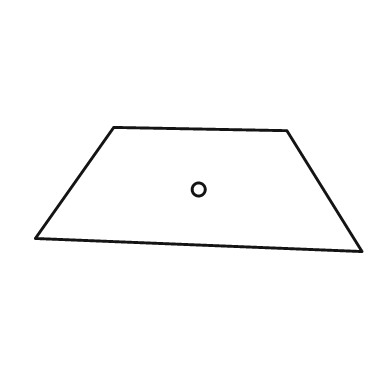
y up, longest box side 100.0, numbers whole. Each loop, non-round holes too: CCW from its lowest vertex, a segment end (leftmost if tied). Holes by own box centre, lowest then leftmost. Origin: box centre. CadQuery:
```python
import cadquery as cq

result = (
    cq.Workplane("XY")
    .moveTo(50.0, -19.0)
    .lineTo(27.0, 18.0)
    .lineTo(-26.0, 19.0)
    .lineTo(-50.0, -15.0)
    .close()
    .moveTo(0.0, 0.0)
    .circle(2.0)
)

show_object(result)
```